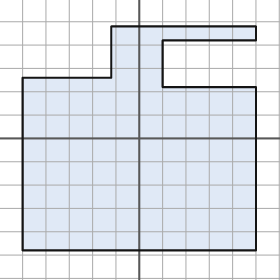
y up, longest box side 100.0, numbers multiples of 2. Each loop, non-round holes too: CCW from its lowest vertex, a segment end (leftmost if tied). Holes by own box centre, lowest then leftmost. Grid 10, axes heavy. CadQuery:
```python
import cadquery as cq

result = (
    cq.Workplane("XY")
    .moveTo(-50.0, -48.0)
    .lineTo(50.0, -48.0)
    .lineTo(50.0, 22.0)
    .lineTo(10.0, 22.0)
    .lineTo(10.0, 42.0)
    .lineTo(50.0, 42.0)
    .lineTo(50.0, 48.0)
    .lineTo(-12.0, 48.0)
    .lineTo(-12.0, 26.0)
    .lineTo(-50.0, 26.0)
    .close()
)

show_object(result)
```